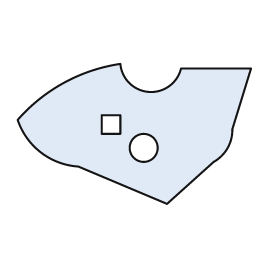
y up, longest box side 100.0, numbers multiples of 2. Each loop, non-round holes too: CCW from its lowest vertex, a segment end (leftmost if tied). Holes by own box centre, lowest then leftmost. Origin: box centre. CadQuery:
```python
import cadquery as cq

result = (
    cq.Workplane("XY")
    .moveTo(14.0, -30.0)
    .lineTo(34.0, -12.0)
    .threePointArc((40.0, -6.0), (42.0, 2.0))
    .lineTo(50.0, 28.0)
    .lineTo(20.0, 28.0)
    .threePointArc((6.0, 18.0), (-6.0, 30.0))
    .threePointArc((-30.0, 22.0), (-50.0, 6.0))
    .threePointArc((-40.0, -8.0), (-24.0, -14.0))
    .close()
    .moveTo(4.0, -6.0)
    .circle(6.0)
    .moveTo(-14.0, 0.0)
    .lineTo(-6.0, 0.0)
    .lineTo(-6.0, 8.0)
    .lineTo(-14.0, 8.0)
    .close()
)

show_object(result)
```